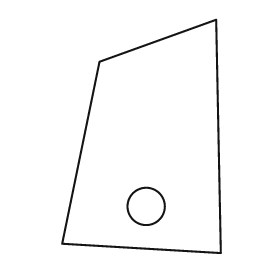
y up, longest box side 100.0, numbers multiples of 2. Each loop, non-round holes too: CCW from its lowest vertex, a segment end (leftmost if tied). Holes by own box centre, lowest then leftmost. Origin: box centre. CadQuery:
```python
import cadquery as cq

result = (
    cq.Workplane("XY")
    .moveTo(34.0, -50.0)
    .lineTo(32.0, 50.0)
    .lineTo(-18.0, 32.0)
    .lineTo(-34.0, -46.0)
    .close()
    .moveTo(2.0, -30.0)
    .circle(8.0)
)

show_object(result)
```